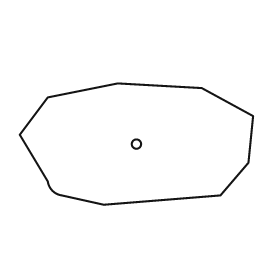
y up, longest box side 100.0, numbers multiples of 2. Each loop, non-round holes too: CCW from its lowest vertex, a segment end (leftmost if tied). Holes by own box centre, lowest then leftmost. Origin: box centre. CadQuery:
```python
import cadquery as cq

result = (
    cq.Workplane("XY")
    .moveTo(-14.0, -26.0)
    .lineTo(36.0, -22.0)
    .lineTo(48.0, -8.0)
    .lineTo(50.0, 12.0)
    .lineTo(28.0, 24.0)
    .lineTo(-8.0, 26.0)
    .lineTo(-38.0, 20.0)
    .lineTo(-50.0, 4.0)
    .lineTo(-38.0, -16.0)
    .threePointArc((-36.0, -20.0), (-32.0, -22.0))
    .close()
    .moveTo(0.0, 0.0)
    .circle(2.0)
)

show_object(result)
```